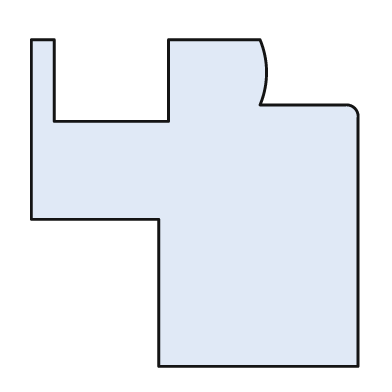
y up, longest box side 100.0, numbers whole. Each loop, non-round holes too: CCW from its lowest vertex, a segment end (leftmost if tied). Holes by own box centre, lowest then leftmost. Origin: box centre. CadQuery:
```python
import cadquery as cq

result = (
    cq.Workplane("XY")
    .moveTo(-11.0, -50.0)
    .lineTo(50.0, -50.0)
    .lineTo(50.0, 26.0)
    .threePointArc((49.0, 29.0), (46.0, 30.0))
    .lineTo(20.0, 30.0)
    .threePointArc((22.0, 40.0), (20.0, 50.0))
    .lineTo(-8.0, 50.0)
    .lineTo(-8.0, 25.0)
    .lineTo(-43.0, 25.0)
    .lineTo(-43.0, 50.0)
    .lineTo(-50.0, 50.0)
    .lineTo(-50.0, -5.0)
    .lineTo(-11.0, -5.0)
    .close()
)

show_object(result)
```